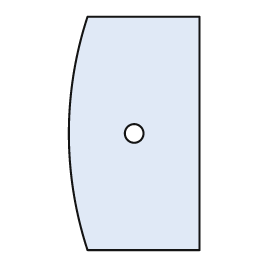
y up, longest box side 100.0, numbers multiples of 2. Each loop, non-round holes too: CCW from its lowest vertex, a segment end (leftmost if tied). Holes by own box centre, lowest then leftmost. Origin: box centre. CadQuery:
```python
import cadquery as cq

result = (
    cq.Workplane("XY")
    .moveTo(-20.0, -50.0)
    .lineTo(28.0, -50.0)
    .lineTo(28.0, 50.0)
    .lineTo(-20.0, 50.0)
    .threePointArc((-28.0, 0.0), (-20.0, -50.0))
    .close()
    .moveTo(0.0, 0.0)
    .circle(4.0)
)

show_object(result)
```